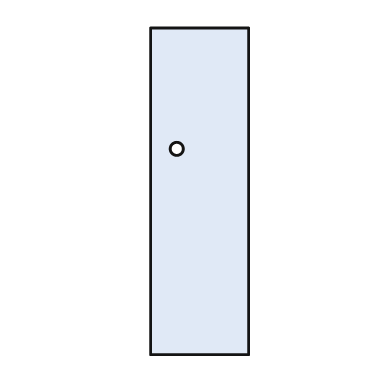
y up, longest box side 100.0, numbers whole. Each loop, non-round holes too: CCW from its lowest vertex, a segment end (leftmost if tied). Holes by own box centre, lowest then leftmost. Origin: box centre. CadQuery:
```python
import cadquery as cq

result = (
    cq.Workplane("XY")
    .moveTo(-15.0, -50.0)
    .lineTo(15.0, -50.0)
    .lineTo(15.0, 50.0)
    .lineTo(-15.0, 50.0)
    .close()
    .moveTo(-7.0, 13.0)
    .circle(2.0)
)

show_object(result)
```